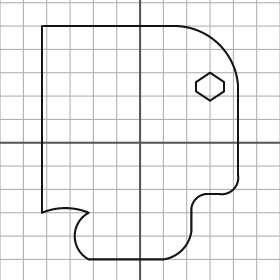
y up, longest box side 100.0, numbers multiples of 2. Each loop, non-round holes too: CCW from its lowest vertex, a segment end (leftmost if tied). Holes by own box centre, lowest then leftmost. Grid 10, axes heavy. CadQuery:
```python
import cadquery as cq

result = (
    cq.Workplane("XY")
    .moveTo(-22.0, -50.0)
    .lineTo(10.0, -50.0)
    .threePointArc((18.0, -46.0), (22.0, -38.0))
    .lineTo(22.0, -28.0)
    .threePointArc((24.0, -24.0), (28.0, -22.0))
    .lineTo(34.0, -22.0)
    .threePointArc((40.0, -20.0), (42.0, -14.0))
    .lineTo(42.0, 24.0)
    .threePointArc((34.0, 42.0), (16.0, 50.0))
    .lineTo(-42.0, 50.0)
    .lineTo(-42.0, -30.0)
    .threePointArc((-32.0, -28.0), (-22.0, -30.0))
    .threePointArc((-28.0, -40.0), (-22.0, -50.0))
    .close()
    .moveTo(30.0, 18.0)
    .lineTo(36.0, 22.0)
    .lineTo(36.0, 26.0)
    .lineTo(30.0, 30.0)
    .lineTo(24.0, 26.0)
    .lineTo(24.0, 22.0)
    .close()
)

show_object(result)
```